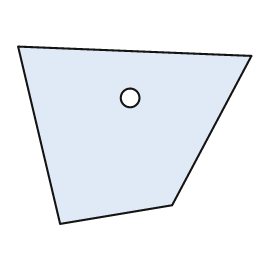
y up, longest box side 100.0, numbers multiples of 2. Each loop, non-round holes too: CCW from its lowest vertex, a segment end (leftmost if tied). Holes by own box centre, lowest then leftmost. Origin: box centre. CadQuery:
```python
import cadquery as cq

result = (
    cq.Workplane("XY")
    .moveTo(-32.0, -38.0)
    .lineTo(16.0, -30.0)
    .lineTo(50.0, 34.0)
    .lineTo(-50.0, 38.0)
    .close()
    .moveTo(-2.0, 16.0)
    .circle(4.0)
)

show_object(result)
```